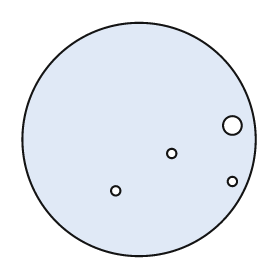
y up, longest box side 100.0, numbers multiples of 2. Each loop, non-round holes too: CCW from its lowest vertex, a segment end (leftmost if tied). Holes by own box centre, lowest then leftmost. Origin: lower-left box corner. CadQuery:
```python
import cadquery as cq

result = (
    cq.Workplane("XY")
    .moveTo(50.0, 50.0)
    .circle(50.0)
    .moveTo(40.0, 28.0)
    .circle(2.0)
    .moveTo(90.0, 32.0)
    .circle(2.0)
    .moveTo(64.0, 44.0)
    .circle(2.0)
    .moveTo(90.0, 56.0)
    .circle(4.0)
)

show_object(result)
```